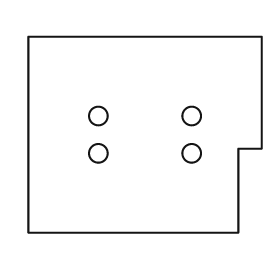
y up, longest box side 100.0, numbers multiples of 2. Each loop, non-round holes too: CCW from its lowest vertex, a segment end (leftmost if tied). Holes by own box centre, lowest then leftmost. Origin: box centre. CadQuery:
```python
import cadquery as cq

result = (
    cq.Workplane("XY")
    .moveTo(-50.0, -42.0)
    .lineTo(40.0, -42.0)
    .lineTo(40.0, -6.0)
    .lineTo(50.0, -6.0)
    .lineTo(50.0, 42.0)
    .lineTo(-50.0, 42.0)
    .close()
    .moveTo(-20.0, -8.0)
    .circle(4.0)
    .moveTo(20.0, -8.0)
    .circle(4.0)
    .moveTo(-20.0, 8.0)
    .circle(4.0)
    .moveTo(20.0, 8.0)
    .circle(4.0)
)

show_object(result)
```